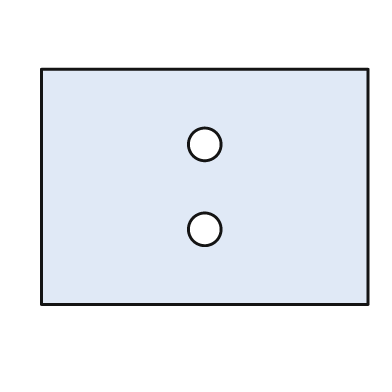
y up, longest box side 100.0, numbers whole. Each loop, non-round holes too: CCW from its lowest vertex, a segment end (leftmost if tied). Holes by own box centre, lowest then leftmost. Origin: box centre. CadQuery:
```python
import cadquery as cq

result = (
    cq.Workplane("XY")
    .moveTo(-50.0, -36.0)
    .lineTo(50.0, -36.0)
    .lineTo(50.0, 36.0)
    .lineTo(-50.0, 36.0)
    .close()
    .moveTo(0.0, -13.0)
    .circle(5.0)
    .moveTo(0.0, 13.0)
    .circle(5.0)
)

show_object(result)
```